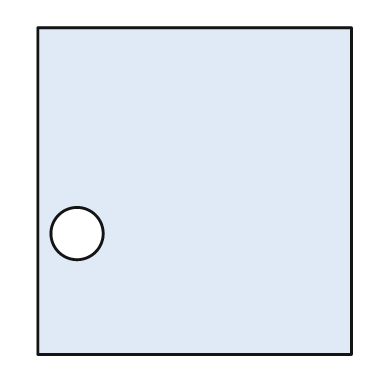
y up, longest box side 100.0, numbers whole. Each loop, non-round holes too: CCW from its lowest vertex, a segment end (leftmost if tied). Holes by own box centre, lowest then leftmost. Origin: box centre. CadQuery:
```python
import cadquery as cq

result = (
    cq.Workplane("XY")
    .moveTo(-48.0, -50.0)
    .lineTo(48.0, -50.0)
    .lineTo(48.0, 50.0)
    .lineTo(-48.0, 50.0)
    .close()
    .moveTo(-36.0, -13.0)
    .circle(8.0)
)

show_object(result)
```